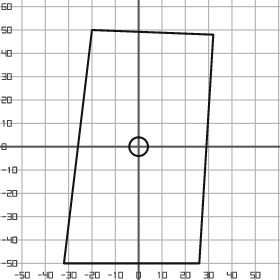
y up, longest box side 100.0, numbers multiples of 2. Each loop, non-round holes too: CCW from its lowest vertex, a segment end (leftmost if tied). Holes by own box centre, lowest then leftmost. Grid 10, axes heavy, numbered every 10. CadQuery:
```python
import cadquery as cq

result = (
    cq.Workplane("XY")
    .moveTo(-32.0, -50.0)
    .lineTo(26.0, -50.0)
    .lineTo(32.0, 48.0)
    .lineTo(-20.0, 50.0)
    .close()
    .moveTo(0.0, 0.0)
    .circle(4.0)
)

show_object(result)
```